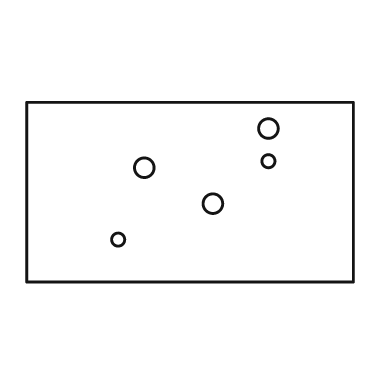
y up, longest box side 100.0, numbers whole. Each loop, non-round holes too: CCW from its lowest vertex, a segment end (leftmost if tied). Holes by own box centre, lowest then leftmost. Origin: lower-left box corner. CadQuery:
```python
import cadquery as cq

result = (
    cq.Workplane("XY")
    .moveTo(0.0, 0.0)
    .lineTo(100.0, 0.0)
    .lineTo(100.0, 55.0)
    .lineTo(0.0, 55.0)
    .close()
    .moveTo(28.0, 13.0)
    .circle(2.0)
    .moveTo(57.0, 24.0)
    .circle(3.0)
    .moveTo(36.0, 35.0)
    .circle(3.0)
    .moveTo(74.0, 37.0)
    .circle(2.0)
    .moveTo(74.0, 47.0)
    .circle(3.0)
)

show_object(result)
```